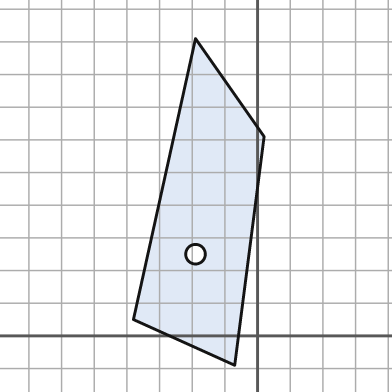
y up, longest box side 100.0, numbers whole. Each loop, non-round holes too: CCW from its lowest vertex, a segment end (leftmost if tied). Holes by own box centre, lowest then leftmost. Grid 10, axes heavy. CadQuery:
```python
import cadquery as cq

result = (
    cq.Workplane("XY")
    .moveTo(-7.0, -9.0)
    .lineTo(2.0, 61.0)
    .lineTo(-19.0, 91.0)
    .lineTo(-38.0, 5.0)
    .close()
    .moveTo(-19.0, 25.0)
    .circle(3.0)
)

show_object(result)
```